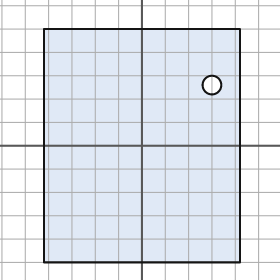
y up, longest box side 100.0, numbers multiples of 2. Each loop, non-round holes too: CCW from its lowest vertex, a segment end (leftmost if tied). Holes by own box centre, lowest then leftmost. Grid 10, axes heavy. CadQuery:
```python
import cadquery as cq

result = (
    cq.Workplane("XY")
    .moveTo(-42.0, -50.0)
    .lineTo(42.0, -50.0)
    .lineTo(42.0, 50.0)
    .lineTo(-42.0, 50.0)
    .close()
    .moveTo(30.0, 26.0)
    .circle(4.0)
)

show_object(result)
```